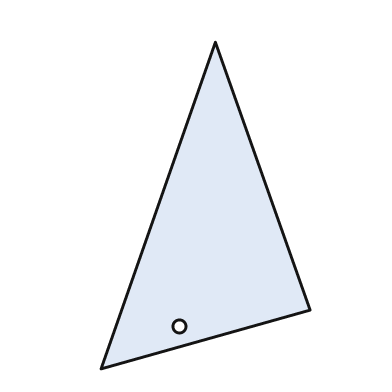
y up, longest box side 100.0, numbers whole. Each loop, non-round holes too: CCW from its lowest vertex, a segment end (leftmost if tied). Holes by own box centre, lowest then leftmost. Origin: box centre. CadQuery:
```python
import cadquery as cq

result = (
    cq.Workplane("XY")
    .moveTo(-32.0, -50.0)
    .lineTo(32.0, -32.0)
    .lineTo(3.0, 50.0)
    .close()
    .moveTo(-8.0, -37.0)
    .circle(2.0)
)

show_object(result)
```